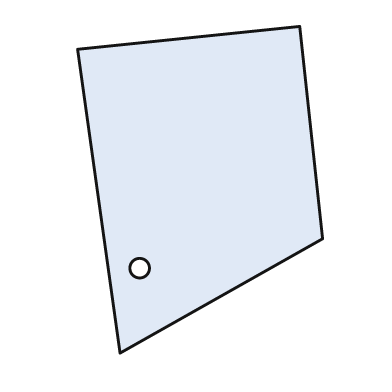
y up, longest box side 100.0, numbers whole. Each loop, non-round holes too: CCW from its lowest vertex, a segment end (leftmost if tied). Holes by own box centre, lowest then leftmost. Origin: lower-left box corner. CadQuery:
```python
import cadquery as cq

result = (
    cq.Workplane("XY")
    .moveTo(13.0, 0.0)
    .lineTo(75.0, 35.0)
    .lineTo(68.0, 100.0)
    .lineTo(0.0, 93.0)
    .close()
    .moveTo(19.0, 26.0)
    .circle(3.0)
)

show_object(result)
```